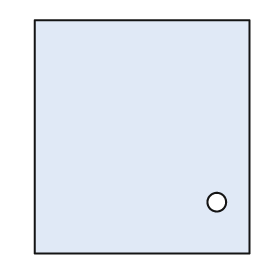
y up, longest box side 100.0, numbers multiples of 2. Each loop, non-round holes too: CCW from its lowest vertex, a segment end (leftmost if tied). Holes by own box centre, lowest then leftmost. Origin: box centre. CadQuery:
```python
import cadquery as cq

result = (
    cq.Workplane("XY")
    .moveTo(-46.0, -50.0)
    .lineTo(46.0, -50.0)
    .lineTo(46.0, 50.0)
    .lineTo(-46.0, 50.0)
    .close()
    .moveTo(32.0, -28.0)
    .circle(4.0)
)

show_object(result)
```